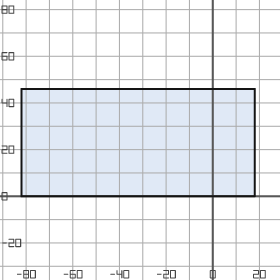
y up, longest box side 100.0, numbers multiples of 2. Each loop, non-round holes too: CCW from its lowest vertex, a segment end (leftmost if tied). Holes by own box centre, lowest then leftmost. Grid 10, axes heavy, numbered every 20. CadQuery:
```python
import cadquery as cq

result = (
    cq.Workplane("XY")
    .moveTo(-82.0, 0.0)
    .lineTo(18.0, 0.0)
    .lineTo(18.0, 46.0)
    .lineTo(-82.0, 46.0)
    .close()
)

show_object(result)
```